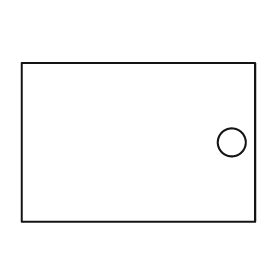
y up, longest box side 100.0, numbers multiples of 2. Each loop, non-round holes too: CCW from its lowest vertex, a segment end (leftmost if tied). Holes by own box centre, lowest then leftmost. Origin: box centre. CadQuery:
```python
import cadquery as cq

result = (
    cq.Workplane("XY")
    .moveTo(-50.0, -34.0)
    .lineTo(50.0, -34.0)
    .lineTo(50.0, 34.0)
    .lineTo(-50.0, 34.0)
    .close()
    .moveTo(40.0, 0.0)
    .circle(6.0)
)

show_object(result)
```